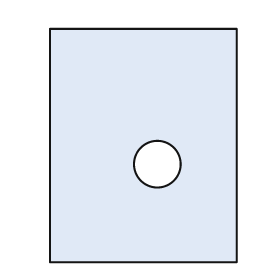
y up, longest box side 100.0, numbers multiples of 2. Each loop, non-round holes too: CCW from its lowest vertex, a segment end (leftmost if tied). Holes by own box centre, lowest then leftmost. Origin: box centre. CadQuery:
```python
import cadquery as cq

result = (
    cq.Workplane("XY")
    .moveTo(-40.0, -50.0)
    .lineTo(40.0, -50.0)
    .lineTo(40.0, 50.0)
    .lineTo(-40.0, 50.0)
    .close()
    .moveTo(6.0, -8.0)
    .circle(10.0)
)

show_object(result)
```